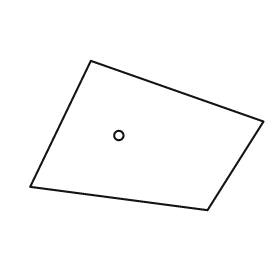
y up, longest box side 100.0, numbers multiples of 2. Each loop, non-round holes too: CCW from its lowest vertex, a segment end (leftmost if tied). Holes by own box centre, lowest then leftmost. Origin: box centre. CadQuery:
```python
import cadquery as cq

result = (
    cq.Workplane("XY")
    .moveTo(26.0, -32.0)
    .lineTo(50.0, 6.0)
    .lineTo(-24.0, 32.0)
    .lineTo(-50.0, -22.0)
    .close()
    .moveTo(-12.0, 0.0)
    .circle(2.0)
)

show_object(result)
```